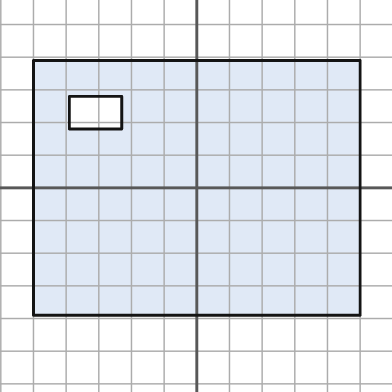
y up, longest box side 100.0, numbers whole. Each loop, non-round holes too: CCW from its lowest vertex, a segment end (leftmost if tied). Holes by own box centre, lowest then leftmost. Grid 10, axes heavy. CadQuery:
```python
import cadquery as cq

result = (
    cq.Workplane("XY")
    .moveTo(-50.0, -39.0)
    .lineTo(50.0, -39.0)
    .lineTo(50.0, 39.0)
    .lineTo(-50.0, 39.0)
    .close()
    .moveTo(-39.0, 18.0)
    .lineTo(-23.0, 18.0)
    .lineTo(-23.0, 28.0)
    .lineTo(-39.0, 28.0)
    .close()
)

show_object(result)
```